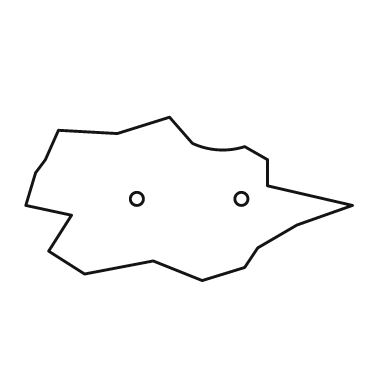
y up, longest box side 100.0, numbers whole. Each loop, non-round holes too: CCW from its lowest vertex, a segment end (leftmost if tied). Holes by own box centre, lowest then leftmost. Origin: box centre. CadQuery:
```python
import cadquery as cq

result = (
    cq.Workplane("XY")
    .moveTo(4.0, -25.0)
    .lineTo(17.0, -21.0)
    .lineTo(21.0, -15.0)
    .lineTo(33.0, -8.0)
    .lineTo(50.0, -2.0)
    .lineTo(24.0, 4.0)
    .lineTo(24.0, 12.0)
    .lineTo(17.0, 16.0)
    .threePointArc((9.0, 15.0), (1.0, 17.0))
    .lineTo(-6.0, 25.0)
    .lineTo(-22.0, 20.0)
    .lineTo(-40.0, 21.0)
    .lineTo(-44.0, 12.0)
    .lineTo(-47.0, 8.0)
    .lineTo(-50.0, -2.0)
    .lineTo(-36.0, -5.0)
    .lineTo(-43.0, -16.0)
    .lineTo(-32.0, -23.0)
    .lineTo(-11.0, -19.0)
    .close()
    .moveTo(-16.0, 0.0)
    .circle(2.0)
    .moveTo(16.0, 0.0)
    .circle(2.0)
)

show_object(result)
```